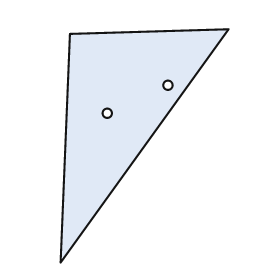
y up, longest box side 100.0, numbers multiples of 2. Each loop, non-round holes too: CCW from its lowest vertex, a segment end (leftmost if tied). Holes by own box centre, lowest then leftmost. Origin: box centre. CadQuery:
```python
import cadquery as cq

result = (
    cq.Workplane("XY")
    .moveTo(-36.0, -50.0)
    .lineTo(36.0, 50.0)
    .lineTo(-32.0, 48.0)
    .close()
    .moveTo(-16.0, 14.0)
    .circle(2.0)
    .moveTo(10.0, 26.0)
    .circle(2.0)
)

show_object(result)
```